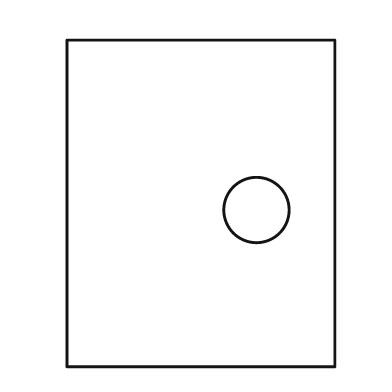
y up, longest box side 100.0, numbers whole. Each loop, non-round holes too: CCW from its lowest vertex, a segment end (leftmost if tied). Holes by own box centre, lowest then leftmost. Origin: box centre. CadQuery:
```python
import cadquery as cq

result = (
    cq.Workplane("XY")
    .moveTo(-41.0, -50.0)
    .lineTo(41.0, -50.0)
    .lineTo(41.0, 50.0)
    .lineTo(-41.0, 50.0)
    .close()
    .moveTo(17.0, -2.0)
    .circle(10.0)
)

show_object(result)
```